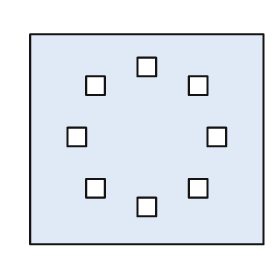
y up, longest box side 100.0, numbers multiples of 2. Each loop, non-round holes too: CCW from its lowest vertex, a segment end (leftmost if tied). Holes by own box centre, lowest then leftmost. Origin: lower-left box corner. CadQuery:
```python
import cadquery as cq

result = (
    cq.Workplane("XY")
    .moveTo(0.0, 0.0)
    .lineTo(100.0, 0.0)
    .lineTo(100.0, 90.0)
    .lineTo(0.0, 90.0)
    .close()
    .moveTo(46.0, 12.0)
    .lineTo(54.0, 12.0)
    .lineTo(54.0, 20.0)
    .lineTo(46.0, 20.0)
    .close()
    .moveTo(24.0, 20.0)
    .lineTo(32.0, 20.0)
    .lineTo(32.0, 28.0)
    .lineTo(24.0, 28.0)
    .close()
    .moveTo(68.0, 20.0)
    .lineTo(76.0, 20.0)
    .lineTo(76.0, 28.0)
    .lineTo(68.0, 28.0)
    .close()
    .moveTo(16.0, 42.0)
    .lineTo(24.0, 42.0)
    .lineTo(24.0, 50.0)
    .lineTo(16.0, 50.0)
    .close()
    .moveTo(76.0, 42.0)
    .lineTo(84.0, 42.0)
    .lineTo(84.0, 50.0)
    .lineTo(76.0, 50.0)
    .close()
    .moveTo(24.0, 64.0)
    .lineTo(32.0, 64.0)
    .lineTo(32.0, 72.0)
    .lineTo(24.0, 72.0)
    .close()
    .moveTo(68.0, 64.0)
    .lineTo(76.0, 64.0)
    .lineTo(76.0, 72.0)
    .lineTo(68.0, 72.0)
    .close()
    .moveTo(46.0, 72.0)
    .lineTo(54.0, 72.0)
    .lineTo(54.0, 80.0)
    .lineTo(46.0, 80.0)
    .close()
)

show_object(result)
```